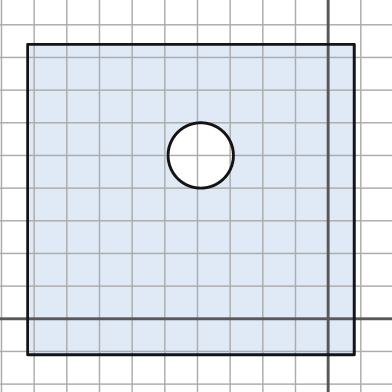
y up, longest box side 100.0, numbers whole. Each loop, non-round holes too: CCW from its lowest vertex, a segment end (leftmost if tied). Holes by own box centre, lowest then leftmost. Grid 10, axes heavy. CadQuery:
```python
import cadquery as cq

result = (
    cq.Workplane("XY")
    .moveTo(-92.0, -11.0)
    .lineTo(8.0, -11.0)
    .lineTo(8.0, 84.0)
    .lineTo(-92.0, 84.0)
    .close()
    .moveTo(-39.0, 50.0)
    .circle(10.0)
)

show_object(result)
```